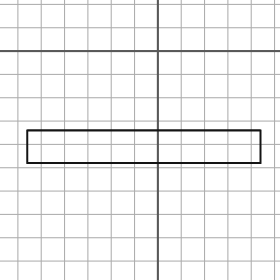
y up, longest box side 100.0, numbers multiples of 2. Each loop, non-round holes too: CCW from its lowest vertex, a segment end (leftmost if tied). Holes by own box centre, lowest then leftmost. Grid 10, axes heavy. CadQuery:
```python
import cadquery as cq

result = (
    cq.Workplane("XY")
    .moveTo(-56.0, -48.0)
    .lineTo(44.0, -48.0)
    .lineTo(44.0, -34.0)
    .lineTo(-56.0, -34.0)
    .close()
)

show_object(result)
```